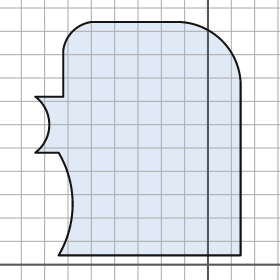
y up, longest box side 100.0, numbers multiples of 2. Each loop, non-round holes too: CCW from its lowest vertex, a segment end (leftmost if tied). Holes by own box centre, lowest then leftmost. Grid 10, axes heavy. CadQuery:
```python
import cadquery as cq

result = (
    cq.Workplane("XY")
    .moveTo(-64.0, 4.0)
    .lineTo(14.0, 4.0)
    .lineTo(14.0, 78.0)
    .threePointArc((6.0, 96.0), (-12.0, 104.0))
    .lineTo(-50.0, 104.0)
    .threePointArc((-58.0, 100.0), (-62.0, 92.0))
    .lineTo(-62.0, 72.0)
    .lineTo(-74.0, 72.0)
    .threePointArc((-68.0, 60.0), (-74.0, 48.0))
    .lineTo(-64.0, 48.0)
    .threePointArc((-58.0, 26.0), (-64.0, 4.0))
    .close()
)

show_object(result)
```